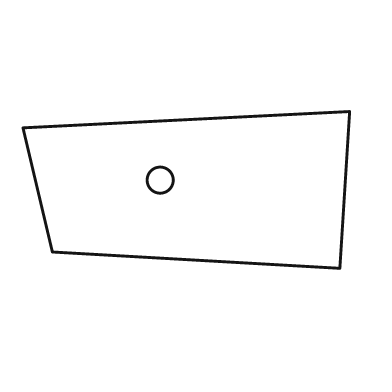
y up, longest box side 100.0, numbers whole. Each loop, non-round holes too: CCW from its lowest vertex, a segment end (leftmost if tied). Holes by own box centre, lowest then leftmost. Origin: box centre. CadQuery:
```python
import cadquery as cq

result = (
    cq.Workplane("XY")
    .moveTo(47.0, -24.0)
    .lineTo(50.0, 24.0)
    .lineTo(-50.0, 19.0)
    .lineTo(-41.0, -19.0)
    .close()
    .moveTo(-8.0, 3.0)
    .circle(4.0)
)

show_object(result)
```